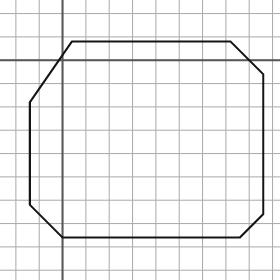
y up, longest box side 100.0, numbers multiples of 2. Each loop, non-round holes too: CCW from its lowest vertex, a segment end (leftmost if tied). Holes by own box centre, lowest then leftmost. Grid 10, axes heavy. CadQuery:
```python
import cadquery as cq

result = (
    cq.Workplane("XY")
    .moveTo(0.0, -76.0)
    .lineTo(76.0, -76.0)
    .lineTo(86.0, -66.0)
    .lineTo(86.0, -6.0)
    .lineTo(72.0, 8.0)
    .lineTo(4.0, 8.0)
    .lineTo(-14.0, -18.0)
    .lineTo(-14.0, -62.0)
    .close()
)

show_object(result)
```